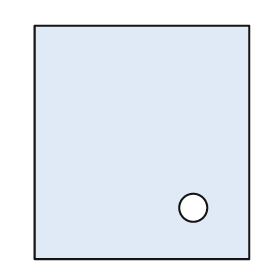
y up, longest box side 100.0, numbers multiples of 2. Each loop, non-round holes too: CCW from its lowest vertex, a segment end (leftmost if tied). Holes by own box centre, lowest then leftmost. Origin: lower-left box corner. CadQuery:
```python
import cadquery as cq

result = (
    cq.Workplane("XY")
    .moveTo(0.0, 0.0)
    .lineTo(92.0, 0.0)
    .lineTo(92.0, 100.0)
    .lineTo(0.0, 100.0)
    .close()
    .moveTo(68.0, 22.0)
    .circle(6.0)
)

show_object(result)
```